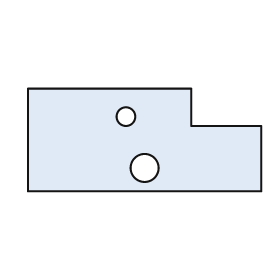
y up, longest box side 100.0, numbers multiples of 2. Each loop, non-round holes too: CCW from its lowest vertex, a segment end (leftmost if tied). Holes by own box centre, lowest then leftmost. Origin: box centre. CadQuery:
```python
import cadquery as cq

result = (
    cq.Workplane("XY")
    .moveTo(-50.0, -22.0)
    .lineTo(50.0, -22.0)
    .lineTo(50.0, 6.0)
    .lineTo(20.0, 6.0)
    .lineTo(20.0, 22.0)
    .lineTo(-50.0, 22.0)
    .close()
    .moveTo(0.0, -12.0)
    .circle(6.0)
    .moveTo(-8.0, 10.0)
    .circle(4.0)
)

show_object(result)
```